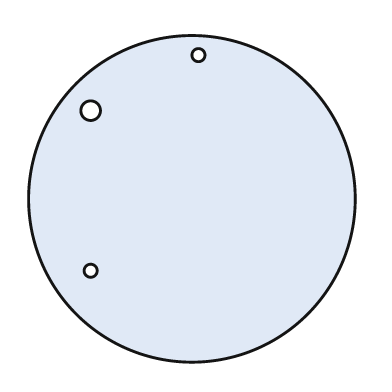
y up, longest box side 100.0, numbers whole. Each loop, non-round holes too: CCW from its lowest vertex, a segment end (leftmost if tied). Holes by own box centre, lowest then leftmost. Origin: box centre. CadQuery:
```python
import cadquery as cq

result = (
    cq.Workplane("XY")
    .moveTo(0.0, 0.0)
    .circle(50.0)
    .moveTo(-31.0, -22.0)
    .circle(2.0)
    .moveTo(-31.0, 27.0)
    .circle(3.0)
    .moveTo(2.0, 44.0)
    .circle(2.0)
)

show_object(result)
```